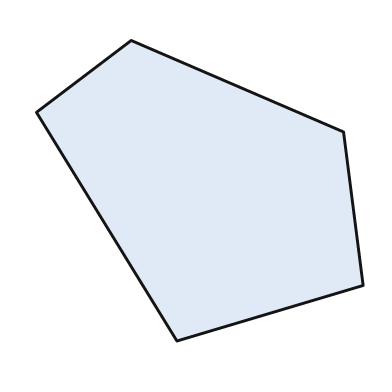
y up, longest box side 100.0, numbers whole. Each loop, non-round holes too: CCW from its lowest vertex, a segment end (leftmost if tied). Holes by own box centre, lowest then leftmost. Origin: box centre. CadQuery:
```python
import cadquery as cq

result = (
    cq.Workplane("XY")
    .moveTo(-7.0, -46.0)
    .lineTo(50.0, -29.0)
    .lineTo(44.0, 18.0)
    .lineTo(-21.0, 46.0)
    .lineTo(-50.0, 24.0)
    .close()
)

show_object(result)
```